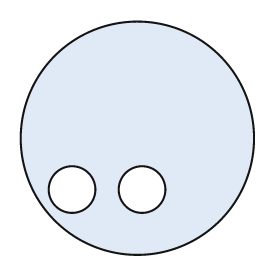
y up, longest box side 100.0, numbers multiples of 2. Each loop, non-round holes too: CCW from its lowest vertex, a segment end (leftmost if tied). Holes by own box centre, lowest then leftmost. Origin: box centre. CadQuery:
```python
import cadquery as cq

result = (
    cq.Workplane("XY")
    .moveTo(0.0, 0.0)
    .circle(50.0)
    .moveTo(-28.0, -22.0)
    .circle(10.0)
    .moveTo(2.0, -22.0)
    .circle(10.0)
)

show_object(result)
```